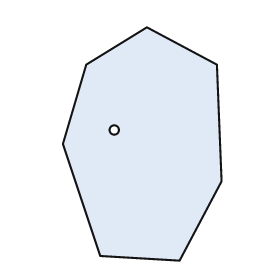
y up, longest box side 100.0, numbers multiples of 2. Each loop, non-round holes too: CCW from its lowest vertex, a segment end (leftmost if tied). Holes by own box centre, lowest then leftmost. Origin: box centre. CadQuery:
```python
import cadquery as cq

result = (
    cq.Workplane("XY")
    .moveTo(16.0, -50.0)
    .lineTo(34.0, -16.0)
    .lineTo(32.0, 34.0)
    .lineTo(2.0, 50.0)
    .lineTo(-24.0, 34.0)
    .lineTo(-34.0, 0.0)
    .lineTo(-18.0, -48.0)
    .close()
    .moveTo(-12.0, 6.0)
    .circle(2.0)
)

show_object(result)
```